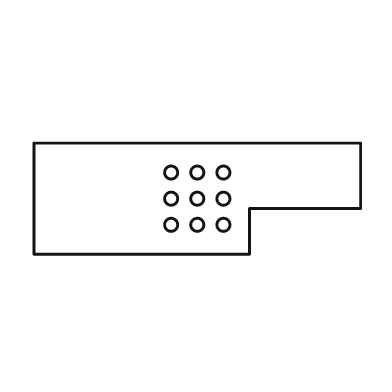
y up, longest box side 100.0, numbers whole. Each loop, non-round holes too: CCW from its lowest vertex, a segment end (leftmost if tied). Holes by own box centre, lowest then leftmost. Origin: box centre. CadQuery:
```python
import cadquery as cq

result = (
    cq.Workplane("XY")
    .moveTo(-50.0, -17.0)
    .lineTo(16.0, -17.0)
    .lineTo(16.0, -3.0)
    .lineTo(50.0, -3.0)
    .lineTo(50.0, 17.0)
    .lineTo(-50.0, 17.0)
    .close()
    .moveTo(-8.0, -8.0)
    .circle(2.0)
    .moveTo(0.0, -8.0)
    .circle(2.0)
    .moveTo(8.0, -8.0)
    .circle(2.0)
    .moveTo(-8.0, 0.0)
    .circle(2.0)
    .moveTo(0.0, 0.0)
    .circle(2.0)
    .moveTo(8.0, 0.0)
    .circle(2.0)
    .moveTo(-8.0, 8.0)
    .circle(2.0)
    .moveTo(0.0, 8.0)
    .circle(2.0)
    .moveTo(8.0, 8.0)
    .circle(2.0)
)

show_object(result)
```